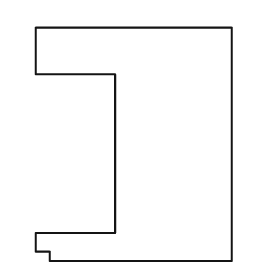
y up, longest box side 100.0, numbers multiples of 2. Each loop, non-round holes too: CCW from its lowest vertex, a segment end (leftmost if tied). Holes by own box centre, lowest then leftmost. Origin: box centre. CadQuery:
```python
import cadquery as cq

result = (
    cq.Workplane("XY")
    .moveTo(-36.0, -50.0)
    .lineTo(42.0, -50.0)
    .lineTo(42.0, 50.0)
    .lineTo(-42.0, 50.0)
    .lineTo(-42.0, 30.0)
    .lineTo(-8.0, 30.0)
    .lineTo(-8.0, -38.0)
    .lineTo(-42.0, -38.0)
    .lineTo(-42.0, -46.0)
    .lineTo(-36.0, -46.0)
    .close()
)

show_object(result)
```